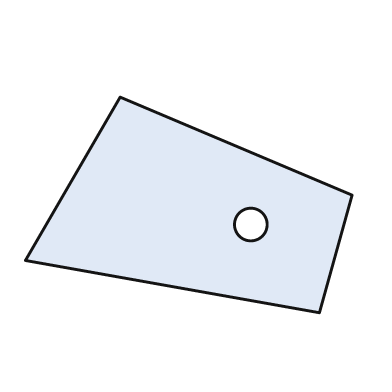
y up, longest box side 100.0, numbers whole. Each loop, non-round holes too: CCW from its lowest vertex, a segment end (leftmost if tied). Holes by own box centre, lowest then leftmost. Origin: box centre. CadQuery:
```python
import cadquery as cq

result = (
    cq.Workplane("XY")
    .moveTo(40.0, -33.0)
    .lineTo(50.0, 3.0)
    .lineTo(-21.0, 33.0)
    .lineTo(-50.0, -17.0)
    .close()
    .moveTo(19.0, -6.0)
    .circle(5.0)
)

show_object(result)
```